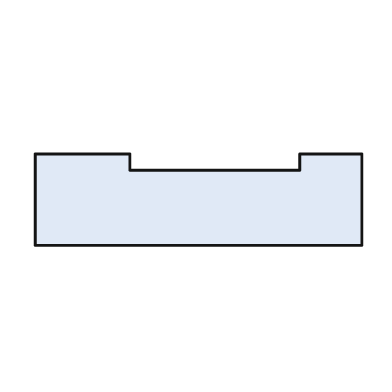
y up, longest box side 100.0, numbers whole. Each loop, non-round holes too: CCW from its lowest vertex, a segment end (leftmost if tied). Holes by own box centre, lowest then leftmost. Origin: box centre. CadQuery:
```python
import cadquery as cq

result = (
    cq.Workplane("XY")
    .moveTo(-50.0, -14.0)
    .lineTo(50.0, -14.0)
    .lineTo(50.0, 14.0)
    .lineTo(31.0, 14.0)
    .lineTo(31.0, 9.0)
    .lineTo(-21.0, 9.0)
    .lineTo(-21.0, 14.0)
    .lineTo(-50.0, 14.0)
    .close()
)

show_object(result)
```